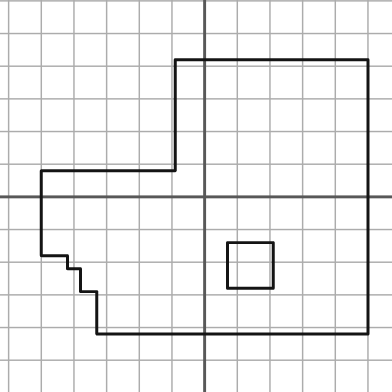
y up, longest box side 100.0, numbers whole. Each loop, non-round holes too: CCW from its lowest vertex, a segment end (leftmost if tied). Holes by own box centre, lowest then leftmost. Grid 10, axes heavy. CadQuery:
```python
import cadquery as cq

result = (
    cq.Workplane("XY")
    .moveTo(-33.0, -42.0)
    .lineTo(50.0, -42.0)
    .lineTo(50.0, 42.0)
    .lineTo(-9.0, 42.0)
    .lineTo(-9.0, 8.0)
    .lineTo(-50.0, 8.0)
    .lineTo(-50.0, -18.0)
    .lineTo(-42.0, -18.0)
    .lineTo(-42.0, -22.0)
    .lineTo(-38.0, -22.0)
    .lineTo(-38.0, -29.0)
    .lineTo(-33.0, -29.0)
    .close()
    .moveTo(7.0, -28.0)
    .lineTo(21.0, -28.0)
    .lineTo(21.0, -14.0)
    .lineTo(7.0, -14.0)
    .close()
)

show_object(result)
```